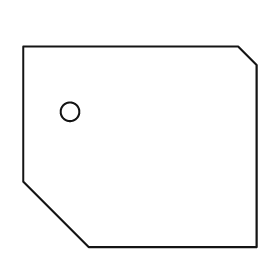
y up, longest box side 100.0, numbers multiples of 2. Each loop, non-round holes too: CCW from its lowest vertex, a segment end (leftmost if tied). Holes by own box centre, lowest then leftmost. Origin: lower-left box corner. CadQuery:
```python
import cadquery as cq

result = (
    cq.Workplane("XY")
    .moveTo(28.0, 0.0)
    .lineTo(100.0, 0.0)
    .lineTo(100.0, 78.0)
    .lineTo(92.0, 86.0)
    .lineTo(0.0, 86.0)
    .lineTo(0.0, 28.0)
    .close()
    .moveTo(20.0, 58.0)
    .circle(4.0)
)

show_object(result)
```